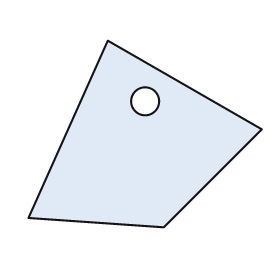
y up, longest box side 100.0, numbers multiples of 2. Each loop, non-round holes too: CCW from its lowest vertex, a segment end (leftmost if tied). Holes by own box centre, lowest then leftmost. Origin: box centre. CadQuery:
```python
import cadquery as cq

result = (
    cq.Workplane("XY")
    .moveTo(8.0, -40.0)
    .lineTo(50.0, 2.0)
    .lineTo(-16.0, 40.0)
    .lineTo(-50.0, -36.0)
    .close()
    .moveTo(0.0, 14.0)
    .circle(6.0)
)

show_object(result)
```